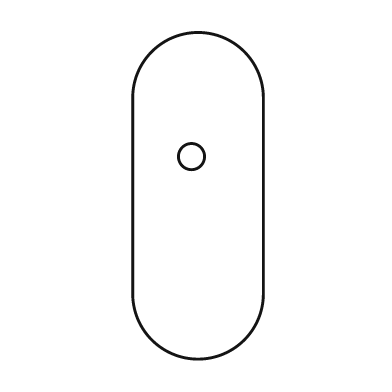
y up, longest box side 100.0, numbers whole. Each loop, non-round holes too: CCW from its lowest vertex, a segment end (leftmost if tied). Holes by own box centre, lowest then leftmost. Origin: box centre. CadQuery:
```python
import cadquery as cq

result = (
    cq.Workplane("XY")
    .moveTo(-20.0, -30.0)
    .threePointArc((0.0, -50.0), (20.0, -30.0))
    .lineTo(20.0, 30.0)
    .threePointArc((0.0, 50.0), (-20.0, 30.0))
    .close()
    .moveTo(-2.0, 12.0)
    .circle(4.0)
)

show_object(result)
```